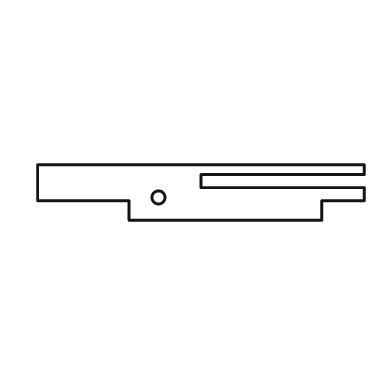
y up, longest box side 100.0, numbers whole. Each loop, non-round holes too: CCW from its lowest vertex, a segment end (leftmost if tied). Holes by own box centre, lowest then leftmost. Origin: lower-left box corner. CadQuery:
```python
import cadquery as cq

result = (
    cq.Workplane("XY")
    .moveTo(28.0, 0.0)
    .lineTo(87.0, 0.0)
    .lineTo(87.0, 6.0)
    .lineTo(100.0, 6.0)
    .lineTo(100.0, 10.0)
    .lineTo(50.0, 10.0)
    .lineTo(50.0, 14.0)
    .lineTo(100.0, 14.0)
    .lineTo(100.0, 17.0)
    .lineTo(0.0, 17.0)
    .lineTo(0.0, 6.0)
    .lineTo(28.0, 6.0)
    .close()
    .moveTo(37.0, 7.0)
    .circle(2.0)
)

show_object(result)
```